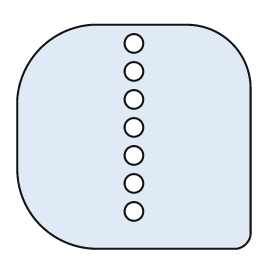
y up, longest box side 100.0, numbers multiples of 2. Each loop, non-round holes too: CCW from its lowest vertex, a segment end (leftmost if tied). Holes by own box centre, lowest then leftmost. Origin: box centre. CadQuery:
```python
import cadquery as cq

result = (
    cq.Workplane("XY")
    .moveTo(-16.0, -48.0)
    .lineTo(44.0, -48.0)
    .threePointArc((48.0, -46.0), (50.0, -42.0))
    .lineTo(50.0, 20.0)
    .threePointArc((42.0, 40.0), (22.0, 48.0))
    .lineTo(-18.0, 48.0)
    .threePointArc((-40.0, 38.0), (-50.0, 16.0))
    .lineTo(-50.0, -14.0)
    .threePointArc((-40.0, -38.0), (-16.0, -48.0))
    .close()
    .moveTo(0.0, -32.0)
    .circle(4.0)
    .moveTo(0.0, -20.0)
    .circle(4.0)
    .moveTo(0.0, -8.0)
    .circle(4.0)
    .moveTo(0.0, 4.0)
    .circle(4.0)
    .moveTo(0.0, 16.0)
    .circle(4.0)
    .moveTo(0.0, 28.0)
    .circle(4.0)
    .moveTo(0.0, 40.0)
    .circle(4.0)
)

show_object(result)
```